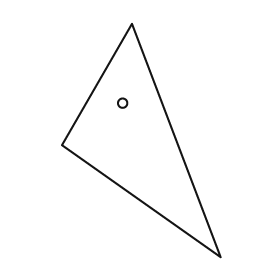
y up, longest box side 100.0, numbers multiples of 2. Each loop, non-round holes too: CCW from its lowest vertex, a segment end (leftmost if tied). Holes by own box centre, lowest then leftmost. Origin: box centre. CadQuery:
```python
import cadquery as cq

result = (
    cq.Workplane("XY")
    .moveTo(34.0, -50.0)
    .lineTo(-4.0, 50.0)
    .lineTo(-34.0, -2.0)
    .close()
    .moveTo(-8.0, 16.0)
    .circle(2.0)
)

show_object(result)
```